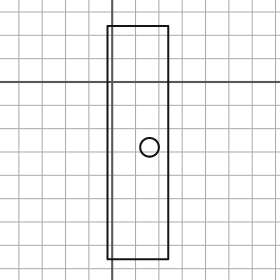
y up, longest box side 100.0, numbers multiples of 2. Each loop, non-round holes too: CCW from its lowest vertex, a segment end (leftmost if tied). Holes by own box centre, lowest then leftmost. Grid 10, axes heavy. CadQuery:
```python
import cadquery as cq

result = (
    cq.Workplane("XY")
    .moveTo(-2.0, -76.0)
    .lineTo(24.0, -76.0)
    .lineTo(24.0, 24.0)
    .lineTo(-2.0, 24.0)
    .close()
    .moveTo(16.0, -28.0)
    .circle(4.0)
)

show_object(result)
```